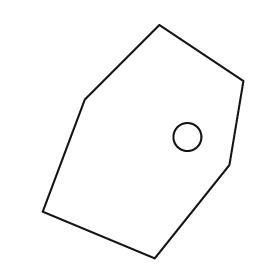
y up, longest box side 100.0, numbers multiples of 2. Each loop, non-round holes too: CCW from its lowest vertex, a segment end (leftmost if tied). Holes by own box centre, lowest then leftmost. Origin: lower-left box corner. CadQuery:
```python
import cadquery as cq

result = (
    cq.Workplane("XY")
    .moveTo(48.0, 0.0)
    .lineTo(80.0, 40.0)
    .lineTo(86.0, 76.0)
    .lineTo(50.0, 100.0)
    .lineTo(18.0, 68.0)
    .lineTo(0.0, 20.0)
    .close()
    .moveTo(62.0, 52.0)
    .circle(6.0)
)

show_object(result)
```